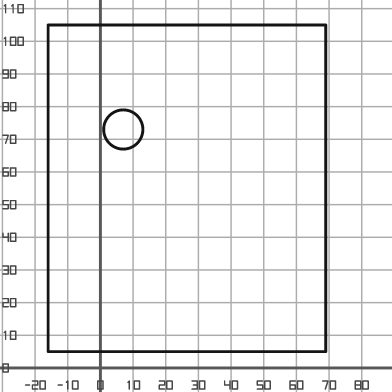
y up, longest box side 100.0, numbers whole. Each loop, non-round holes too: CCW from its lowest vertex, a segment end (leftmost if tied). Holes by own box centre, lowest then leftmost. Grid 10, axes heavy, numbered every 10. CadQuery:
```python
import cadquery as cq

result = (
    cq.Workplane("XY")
    .moveTo(-16.0, 5.0)
    .lineTo(69.0, 5.0)
    .lineTo(69.0, 105.0)
    .lineTo(-16.0, 105.0)
    .close()
    .moveTo(7.0, 73.0)
    .circle(6.0)
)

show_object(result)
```